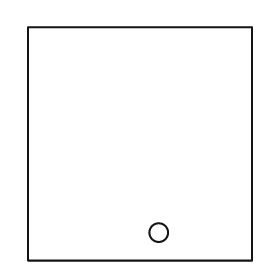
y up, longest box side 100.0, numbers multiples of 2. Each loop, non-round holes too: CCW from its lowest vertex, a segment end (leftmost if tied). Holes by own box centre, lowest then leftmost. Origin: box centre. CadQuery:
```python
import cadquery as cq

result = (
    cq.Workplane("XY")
    .moveTo(-48.0, -50.0)
    .lineTo(48.0, -50.0)
    .lineTo(48.0, 50.0)
    .lineTo(-48.0, 50.0)
    .close()
    .moveTo(8.0, -38.0)
    .circle(4.0)
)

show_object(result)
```